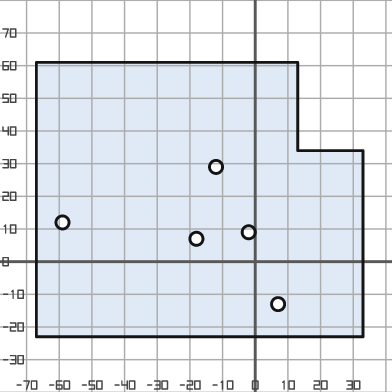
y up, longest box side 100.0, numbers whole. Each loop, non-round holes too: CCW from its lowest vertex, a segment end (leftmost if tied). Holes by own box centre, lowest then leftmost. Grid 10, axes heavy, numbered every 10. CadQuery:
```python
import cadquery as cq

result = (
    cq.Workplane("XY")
    .moveTo(-67.0, -23.0)
    .lineTo(33.0, -23.0)
    .lineTo(33.0, 34.0)
    .lineTo(13.0, 34.0)
    .lineTo(13.0, 61.0)
    .lineTo(-67.0, 61.0)
    .close()
    .moveTo(7.0, -13.0)
    .circle(2.0)
    .moveTo(-18.0, 7.0)
    .circle(2.0)
    .moveTo(-2.0, 9.0)
    .circle(2.0)
    .moveTo(-59.0, 12.0)
    .circle(2.0)
    .moveTo(-12.0, 29.0)
    .circle(2.0)
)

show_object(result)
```